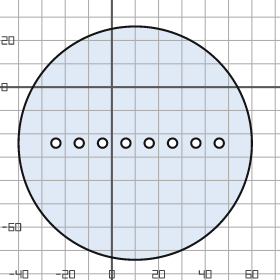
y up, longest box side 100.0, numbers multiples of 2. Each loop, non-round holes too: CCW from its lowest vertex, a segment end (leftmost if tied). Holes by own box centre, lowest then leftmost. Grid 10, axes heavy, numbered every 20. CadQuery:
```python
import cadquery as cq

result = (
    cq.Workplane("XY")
    .moveTo(10.0, -24.0)
    .circle(50.0)
    .moveTo(-24.0, -24.0)
    .circle(2.0)
    .moveTo(-14.0, -24.0)
    .circle(2.0)
    .moveTo(-4.0, -24.0)
    .circle(2.0)
    .moveTo(6.0, -24.0)
    .circle(2.0)
    .moveTo(16.0, -24.0)
    .circle(2.0)
    .moveTo(26.0, -24.0)
    .circle(2.0)
    .moveTo(36.0, -24.0)
    .circle(2.0)
    .moveTo(46.0, -24.0)
    .circle(2.0)
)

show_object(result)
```